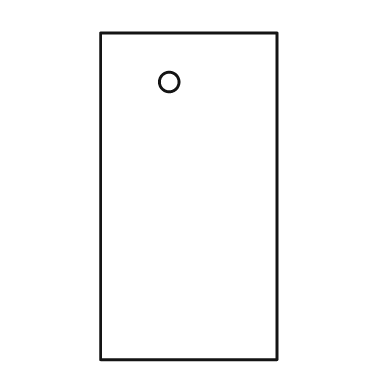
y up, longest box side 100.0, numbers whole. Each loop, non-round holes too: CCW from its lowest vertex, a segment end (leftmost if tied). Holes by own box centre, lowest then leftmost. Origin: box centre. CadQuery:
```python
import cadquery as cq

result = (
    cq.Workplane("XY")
    .moveTo(-27.0, -50.0)
    .lineTo(27.0, -50.0)
    .lineTo(27.0, 50.0)
    .lineTo(-27.0, 50.0)
    .close()
    .moveTo(-6.0, 35.0)
    .circle(3.0)
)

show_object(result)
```